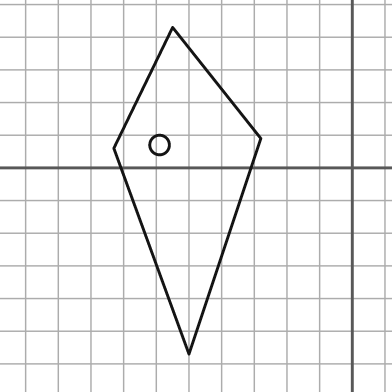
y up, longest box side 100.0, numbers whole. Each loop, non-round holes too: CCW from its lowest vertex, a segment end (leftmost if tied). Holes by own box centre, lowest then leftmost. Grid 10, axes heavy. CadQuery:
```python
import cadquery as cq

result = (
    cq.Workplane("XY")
    .moveTo(-50.0, -57.0)
    .lineTo(-28.0, 9.0)
    .lineTo(-55.0, 43.0)
    .lineTo(-73.0, 6.0)
    .close()
    .moveTo(-59.0, 7.0)
    .circle(3.0)
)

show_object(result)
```